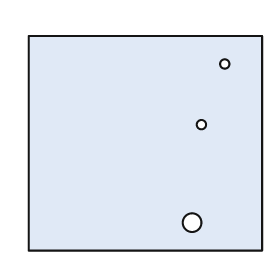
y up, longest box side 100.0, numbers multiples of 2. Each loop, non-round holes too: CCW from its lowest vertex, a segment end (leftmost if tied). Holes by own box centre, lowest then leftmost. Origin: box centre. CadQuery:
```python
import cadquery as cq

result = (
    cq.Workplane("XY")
    .moveTo(-50.0, -46.0)
    .lineTo(50.0, -46.0)
    .lineTo(50.0, 46.0)
    .lineTo(-50.0, 46.0)
    .close()
    .moveTo(20.0, -34.0)
    .circle(4.0)
    .moveTo(24.0, 8.0)
    .circle(2.0)
    .moveTo(34.0, 34.0)
    .circle(2.0)
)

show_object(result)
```